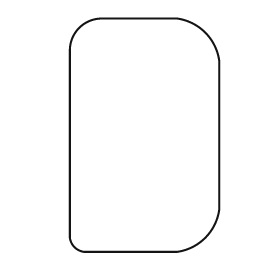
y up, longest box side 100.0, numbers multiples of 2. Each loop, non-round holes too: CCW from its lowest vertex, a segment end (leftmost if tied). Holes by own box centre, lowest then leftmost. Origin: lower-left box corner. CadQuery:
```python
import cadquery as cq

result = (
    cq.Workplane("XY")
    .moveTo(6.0, 0.0)
    .lineTo(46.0, 0.0)
    .threePointArc((58.0, 6.0), (64.0, 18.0))
    .lineTo(64.0, 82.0)
    .threePointArc((58.0, 94.0), (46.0, 100.0))
    .lineTo(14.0, 100.0)
    .threePointArc((4.0, 96.0), (0.0, 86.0))
    .lineTo(0.0, 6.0)
    .threePointArc((2.0, 2.0), (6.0, 0.0))
    .close()
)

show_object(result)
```